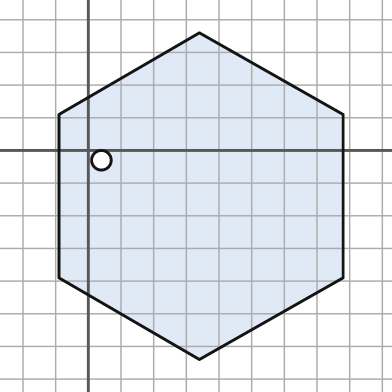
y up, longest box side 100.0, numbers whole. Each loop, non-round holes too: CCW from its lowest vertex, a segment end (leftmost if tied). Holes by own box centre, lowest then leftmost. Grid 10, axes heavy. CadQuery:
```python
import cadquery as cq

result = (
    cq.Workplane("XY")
    .moveTo(34.0, -64.0)
    .lineTo(78.0, -39.0)
    .lineTo(78.0, 11.0)
    .lineTo(34.0, 36.0)
    .lineTo(-9.0, 11.0)
    .lineTo(-9.0, -39.0)
    .close()
    .moveTo(4.0, -3.0)
    .circle(3.0)
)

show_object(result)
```